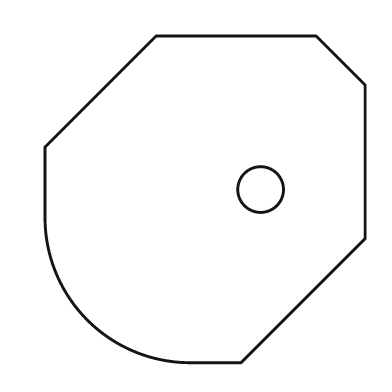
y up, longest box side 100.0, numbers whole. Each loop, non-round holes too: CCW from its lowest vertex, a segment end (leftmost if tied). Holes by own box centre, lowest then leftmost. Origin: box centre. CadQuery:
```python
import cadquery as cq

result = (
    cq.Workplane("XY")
    .moveTo(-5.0, -50.0)
    .lineTo(11.0, -50.0)
    .lineTo(49.0, -12.0)
    .lineTo(49.0, 35.0)
    .lineTo(34.0, 50.0)
    .lineTo(-15.0, 50.0)
    .lineTo(-49.0, 16.0)
    .lineTo(-49.0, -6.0)
    .threePointArc((-36.0, -37.0), (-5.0, -50.0))
    .close()
    .moveTo(17.0, 3.0)
    .circle(7.0)
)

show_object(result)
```